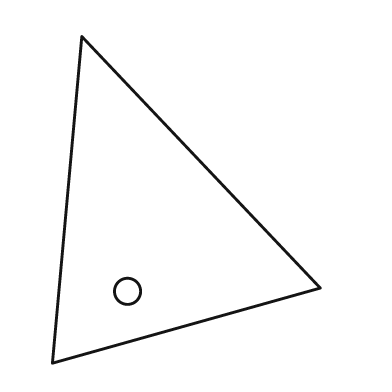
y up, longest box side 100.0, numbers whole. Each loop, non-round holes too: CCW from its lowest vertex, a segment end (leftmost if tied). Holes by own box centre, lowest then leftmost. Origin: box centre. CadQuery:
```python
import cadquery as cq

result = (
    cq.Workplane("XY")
    .moveTo(-41.0, -50.0)
    .lineTo(41.0, -27.0)
    .lineTo(-32.0, 50.0)
    .close()
    .moveTo(-18.0, -28.0)
    .circle(4.0)
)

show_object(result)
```